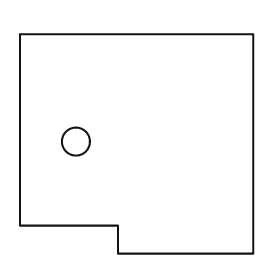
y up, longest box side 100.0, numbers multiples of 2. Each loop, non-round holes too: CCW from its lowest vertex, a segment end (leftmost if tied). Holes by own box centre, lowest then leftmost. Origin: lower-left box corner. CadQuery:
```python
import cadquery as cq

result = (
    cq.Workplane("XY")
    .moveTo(42.0, 0.0)
    .lineTo(100.0, 0.0)
    .lineTo(100.0, 94.0)
    .lineTo(0.0, 94.0)
    .lineTo(0.0, 12.0)
    .lineTo(42.0, 12.0)
    .close()
    .moveTo(24.0, 48.0)
    .circle(6.0)
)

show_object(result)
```